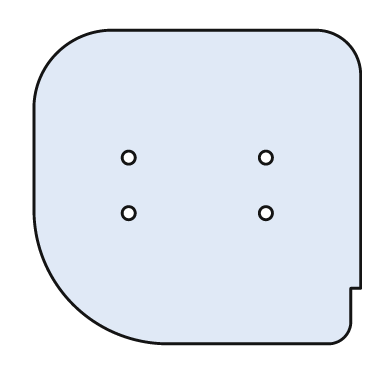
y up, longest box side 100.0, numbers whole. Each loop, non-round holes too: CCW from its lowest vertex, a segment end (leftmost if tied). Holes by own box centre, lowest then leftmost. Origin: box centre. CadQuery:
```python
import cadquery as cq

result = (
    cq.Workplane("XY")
    .moveTo(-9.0, -48.0)
    .lineTo(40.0, -48.0)
    .threePointArc((45.0, -46.0), (47.0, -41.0))
    .lineTo(47.0, -31.0)
    .lineTo(50.0, -31.0)
    .lineTo(50.0, 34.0)
    .threePointArc((46.0, 44.0), (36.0, 48.0))
    .lineTo(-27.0, 48.0)
    .threePointArc((-43.0, 41.0), (-50.0, 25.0))
    .lineTo(-50.0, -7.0)
    .threePointArc((-38.0, -36.0), (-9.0, -48.0))
    .close()
    .moveTo(-21.0, -8.0)
    .circle(2.0)
    .moveTo(21.0, -8.0)
    .circle(2.0)
    .moveTo(-21.0, 9.0)
    .circle(2.0)
    .moveTo(21.0, 9.0)
    .circle(2.0)
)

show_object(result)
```